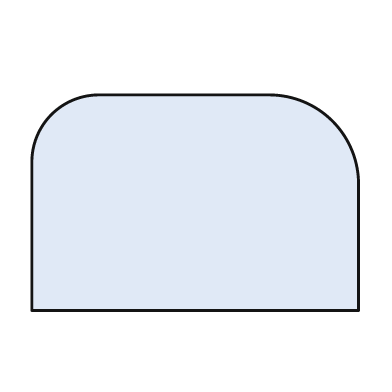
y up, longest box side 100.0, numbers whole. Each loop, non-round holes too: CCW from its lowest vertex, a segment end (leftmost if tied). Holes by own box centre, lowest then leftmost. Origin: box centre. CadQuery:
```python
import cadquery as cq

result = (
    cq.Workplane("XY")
    .moveTo(-50.0, -33.0)
    .lineTo(50.0, -33.0)
    .lineTo(50.0, 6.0)
    .threePointArc((42.0, 25.0), (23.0, 33.0))
    .lineTo(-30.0, 33.0)
    .threePointArc((-44.0, 27.0), (-50.0, 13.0))
    .close()
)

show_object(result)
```